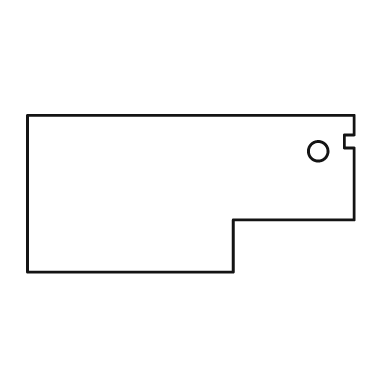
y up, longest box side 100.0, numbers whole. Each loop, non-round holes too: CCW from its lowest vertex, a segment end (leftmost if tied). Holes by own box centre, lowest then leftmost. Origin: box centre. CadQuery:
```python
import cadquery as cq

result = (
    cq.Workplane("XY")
    .moveTo(-50.0, -24.0)
    .lineTo(13.0, -24.0)
    .lineTo(13.0, -8.0)
    .lineTo(50.0, -8.0)
    .lineTo(50.0, 14.0)
    .lineTo(47.0, 14.0)
    .lineTo(47.0, 18.0)
    .lineTo(50.0, 18.0)
    .lineTo(50.0, 24.0)
    .lineTo(-50.0, 24.0)
    .close()
    .moveTo(39.0, 13.0)
    .circle(3.0)
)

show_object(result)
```